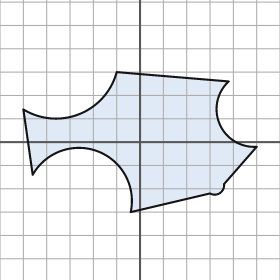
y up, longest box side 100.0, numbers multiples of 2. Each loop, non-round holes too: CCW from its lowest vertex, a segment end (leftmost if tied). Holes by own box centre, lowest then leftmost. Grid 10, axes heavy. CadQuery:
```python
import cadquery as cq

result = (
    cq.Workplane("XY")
    .moveTo(-4.0, -30.0)
    .lineTo(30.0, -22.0)
    .threePointArc((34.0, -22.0), (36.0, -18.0))
    .lineTo(50.0, -2.0)
    .threePointArc((34.0, 8.0), (38.0, 26.0))
    .lineTo(-10.0, 30.0)
    .threePointArc((-26.0, 12.0), (-50.0, 14.0))
    .lineTo(-46.0, -14.0)
    .threePointArc((-18.0, -4.0), (-4.0, -30.0))
    .close()
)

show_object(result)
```